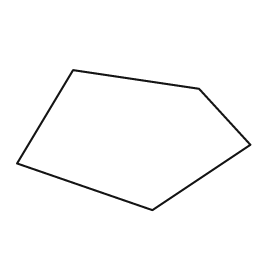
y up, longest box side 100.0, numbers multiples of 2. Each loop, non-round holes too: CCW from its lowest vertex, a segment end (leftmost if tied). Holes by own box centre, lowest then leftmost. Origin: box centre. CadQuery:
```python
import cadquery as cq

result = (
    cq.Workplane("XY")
    .moveTo(8.0, -30.0)
    .lineTo(50.0, -2.0)
    .lineTo(28.0, 22.0)
    .lineTo(-26.0, 30.0)
    .lineTo(-50.0, -10.0)
    .close()
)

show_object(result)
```